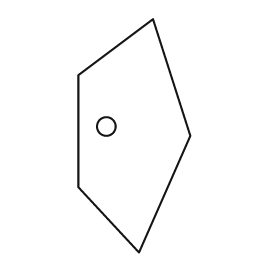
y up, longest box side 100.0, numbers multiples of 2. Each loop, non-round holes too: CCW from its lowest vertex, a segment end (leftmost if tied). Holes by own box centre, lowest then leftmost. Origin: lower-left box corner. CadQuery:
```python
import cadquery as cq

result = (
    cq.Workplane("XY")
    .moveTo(26.0, 0.0)
    .lineTo(48.0, 50.0)
    .lineTo(32.0, 100.0)
    .lineTo(0.0, 76.0)
    .lineTo(0.0, 28.0)
    .close()
    .moveTo(12.0, 54.0)
    .circle(4.0)
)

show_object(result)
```